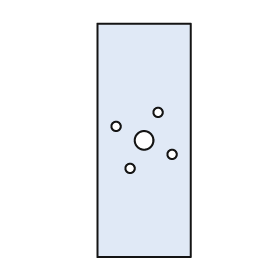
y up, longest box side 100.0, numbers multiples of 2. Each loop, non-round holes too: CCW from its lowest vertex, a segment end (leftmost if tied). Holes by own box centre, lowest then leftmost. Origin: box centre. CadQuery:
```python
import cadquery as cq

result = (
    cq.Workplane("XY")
    .moveTo(-20.0, -50.0)
    .lineTo(20.0, -50.0)
    .lineTo(20.0, 50.0)
    .lineTo(-20.0, 50.0)
    .close()
    .moveTo(-6.0, -12.0)
    .circle(2.0)
    .moveTo(12.0, -6.0)
    .circle(2.0)
    .moveTo(0.0, 0.0)
    .circle(4.0)
    .moveTo(-12.0, 6.0)
    .circle(2.0)
    .moveTo(6.0, 12.0)
    .circle(2.0)
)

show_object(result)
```